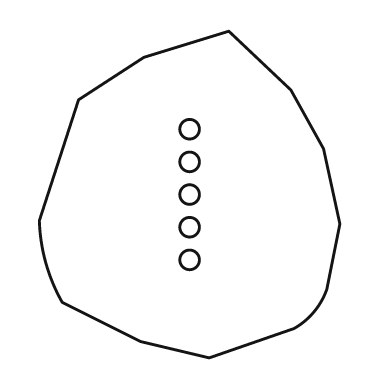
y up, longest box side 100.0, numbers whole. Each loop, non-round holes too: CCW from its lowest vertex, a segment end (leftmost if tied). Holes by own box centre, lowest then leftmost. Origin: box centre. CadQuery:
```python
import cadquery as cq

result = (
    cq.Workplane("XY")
    .moveTo(6.0, -50.0)
    .lineTo(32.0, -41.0)
    .threePointArc((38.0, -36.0), (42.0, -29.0))
    .lineTo(46.0, -9.0)
    .lineTo(41.0, 14.0)
    .lineTo(31.0, 32.0)
    .lineTo(12.0, 50.0)
    .lineTo(-14.0, 42.0)
    .lineTo(-34.0, 29.0)
    .lineTo(-46.0, -8.0)
    .threePointArc((-44.0, -21.0), (-39.0, -33.0))
    .lineTo(-15.0, -45.0)
    .close()
    .moveTo(0.0, -20.0)
    .circle(3.0)
    .moveTo(0.0, -10.0)
    .circle(3.0)
    .moveTo(0.0, 0.0)
    .circle(3.0)
    .moveTo(0.0, 10.0)
    .circle(3.0)
    .moveTo(0.0, 20.0)
    .circle(3.0)
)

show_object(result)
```